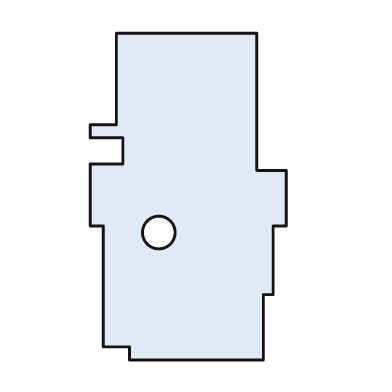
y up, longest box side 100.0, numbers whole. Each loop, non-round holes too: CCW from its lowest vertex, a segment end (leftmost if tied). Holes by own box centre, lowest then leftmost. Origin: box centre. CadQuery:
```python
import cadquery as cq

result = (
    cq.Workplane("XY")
    .moveTo(-18.0, -50.0)
    .lineTo(23.0, -50.0)
    .lineTo(23.0, -30.0)
    .lineTo(26.0, -30.0)
    .lineTo(26.0, -9.0)
    .lineTo(30.0, -9.0)
    .lineTo(30.0, 8.0)
    .lineTo(21.0, 8.0)
    .lineTo(21.0, 50.0)
    .lineTo(-22.0, 50.0)
    .lineTo(-22.0, 22.0)
    .lineTo(-30.0, 22.0)
    .lineTo(-30.0, 18.0)
    .lineTo(-20.0, 18.0)
    .lineTo(-20.0, 10.0)
    .lineTo(-30.0, 10.0)
    .lineTo(-30.0, -9.0)
    .lineTo(-26.0, -9.0)
    .lineTo(-26.0, -46.0)
    .lineTo(-18.0, -46.0)
    .close()
    .moveTo(-9.0, -11.0)
    .circle(5.0)
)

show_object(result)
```